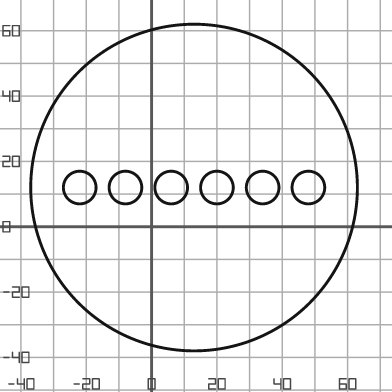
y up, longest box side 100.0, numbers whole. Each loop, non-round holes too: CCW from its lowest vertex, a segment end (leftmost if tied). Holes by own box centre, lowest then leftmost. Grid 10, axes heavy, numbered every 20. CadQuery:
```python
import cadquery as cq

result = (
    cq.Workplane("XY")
    .moveTo(13.0, 12.0)
    .circle(50.0)
    .moveTo(-22.0, 12.0)
    .circle(5.0)
    .moveTo(-8.0, 12.0)
    .circle(5.0)
    .moveTo(6.0, 12.0)
    .circle(5.0)
    .moveTo(20.0, 12.0)
    .circle(5.0)
    .moveTo(34.0, 12.0)
    .circle(5.0)
    .moveTo(48.0, 12.0)
    .circle(5.0)
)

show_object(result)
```